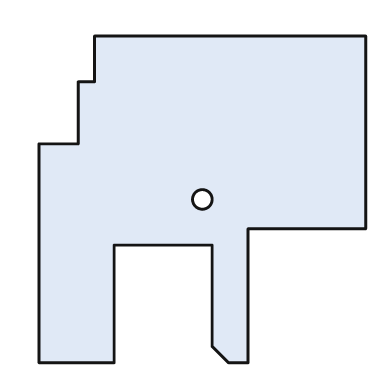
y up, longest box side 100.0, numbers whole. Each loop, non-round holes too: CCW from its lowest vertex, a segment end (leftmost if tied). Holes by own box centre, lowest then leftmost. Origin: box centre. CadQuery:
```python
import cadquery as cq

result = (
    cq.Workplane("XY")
    .moveTo(-50.0, -50.0)
    .lineTo(-27.0, -50.0)
    .lineTo(-27.0, -14.0)
    .lineTo(3.0, -14.0)
    .lineTo(3.0, -45.0)
    .lineTo(8.0, -50.0)
    .lineTo(14.0, -50.0)
    .lineTo(14.0, -9.0)
    .lineTo(50.0, -9.0)
    .lineTo(50.0, 50.0)
    .lineTo(-33.0, 50.0)
    .lineTo(-33.0, 36.0)
    .lineTo(-38.0, 36.0)
    .lineTo(-38.0, 17.0)
    .lineTo(-50.0, 17.0)
    .close()
    .moveTo(0.0, 0.0)
    .circle(3.0)
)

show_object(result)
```